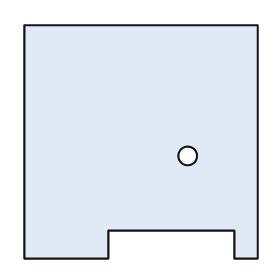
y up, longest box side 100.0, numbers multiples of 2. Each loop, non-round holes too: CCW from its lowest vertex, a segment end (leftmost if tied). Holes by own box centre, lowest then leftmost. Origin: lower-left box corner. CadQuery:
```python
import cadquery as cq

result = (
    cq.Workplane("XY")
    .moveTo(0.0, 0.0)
    .lineTo(36.0, 0.0)
    .lineTo(36.0, 12.0)
    .lineTo(90.0, 12.0)
    .lineTo(90.0, 0.0)
    .lineTo(100.0, 0.0)
    .lineTo(100.0, 100.0)
    .lineTo(0.0, 100.0)
    .close()
    .moveTo(70.0, 44.0)
    .circle(4.0)
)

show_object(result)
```